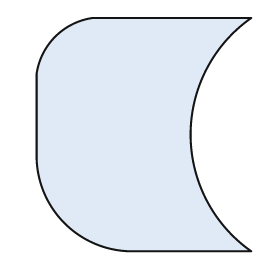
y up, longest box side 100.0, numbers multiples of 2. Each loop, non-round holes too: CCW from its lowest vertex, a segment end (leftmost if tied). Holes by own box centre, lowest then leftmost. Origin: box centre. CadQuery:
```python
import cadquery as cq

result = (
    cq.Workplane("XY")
    .moveTo(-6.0, -50.0)
    .lineTo(46.0, -50.0)
    .threePointArc((20.0, 0.0), (46.0, 50.0))
    .lineTo(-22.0, 50.0)
    .threePointArc((-38.0, 42.0), (-46.0, 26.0))
    .lineTo(-46.0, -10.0)
    .threePointArc((-34.0, -38.0), (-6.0, -50.0))
    .close()
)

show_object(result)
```